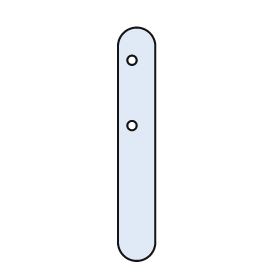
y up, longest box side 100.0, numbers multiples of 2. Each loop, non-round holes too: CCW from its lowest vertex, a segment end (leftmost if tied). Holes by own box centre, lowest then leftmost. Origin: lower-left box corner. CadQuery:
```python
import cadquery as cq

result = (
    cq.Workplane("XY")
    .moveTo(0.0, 8.0)
    .threePointArc((8.0, 0.0), (16.0, 8.0))
    .lineTo(16.0, 92.0)
    .threePointArc((8.0, 100.0), (0.0, 92.0))
    .close()
    .moveTo(6.0, 58.0)
    .circle(2.0)
    .moveTo(6.0, 86.0)
    .circle(2.0)
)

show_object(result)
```